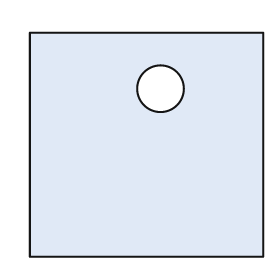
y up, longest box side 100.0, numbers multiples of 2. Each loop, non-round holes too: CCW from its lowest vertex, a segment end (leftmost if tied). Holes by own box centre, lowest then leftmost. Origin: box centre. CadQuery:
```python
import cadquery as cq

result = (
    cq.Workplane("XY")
    .moveTo(-50.0, -48.0)
    .lineTo(50.0, -48.0)
    .lineTo(50.0, 48.0)
    .lineTo(-50.0, 48.0)
    .close()
    .moveTo(6.0, 24.0)
    .circle(10.0)
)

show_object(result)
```